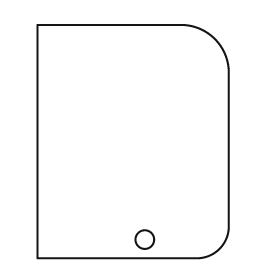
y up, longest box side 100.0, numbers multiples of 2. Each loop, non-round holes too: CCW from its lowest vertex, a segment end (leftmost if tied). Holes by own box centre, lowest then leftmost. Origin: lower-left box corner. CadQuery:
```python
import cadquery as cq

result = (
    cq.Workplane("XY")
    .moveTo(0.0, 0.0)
    .lineTo(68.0, 0.0)
    .threePointArc((78.0, 4.0), (82.0, 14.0))
    .lineTo(82.0, 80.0)
    .threePointArc((76.0, 94.0), (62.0, 100.0))
    .lineTo(0.0, 100.0)
    .close()
    .moveTo(46.0, 8.0)
    .circle(4.0)
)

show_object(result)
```